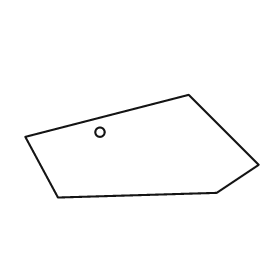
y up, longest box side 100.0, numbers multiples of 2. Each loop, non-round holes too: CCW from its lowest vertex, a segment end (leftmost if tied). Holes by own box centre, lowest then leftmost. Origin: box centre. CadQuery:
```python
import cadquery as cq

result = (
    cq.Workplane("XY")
    .moveTo(-36.0, -22.0)
    .lineTo(32.0, -20.0)
    .lineTo(50.0, -8.0)
    .lineTo(20.0, 22.0)
    .lineTo(-50.0, 4.0)
    .close()
    .moveTo(-18.0, 6.0)
    .circle(2.0)
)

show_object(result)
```